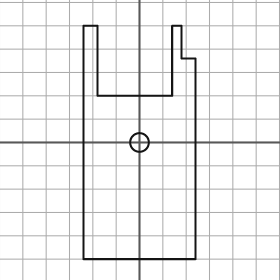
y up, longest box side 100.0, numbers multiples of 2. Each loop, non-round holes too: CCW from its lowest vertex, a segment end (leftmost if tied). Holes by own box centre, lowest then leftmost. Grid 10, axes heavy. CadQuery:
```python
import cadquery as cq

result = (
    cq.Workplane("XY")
    .moveTo(-24.0, -50.0)
    .lineTo(24.0, -50.0)
    .lineTo(24.0, 36.0)
    .lineTo(18.0, 36.0)
    .lineTo(18.0, 50.0)
    .lineTo(14.0, 50.0)
    .lineTo(14.0, 20.0)
    .lineTo(-18.0, 20.0)
    .lineTo(-18.0, 50.0)
    .lineTo(-24.0, 50.0)
    .close()
    .moveTo(0.0, 0.0)
    .circle(4.0)
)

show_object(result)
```